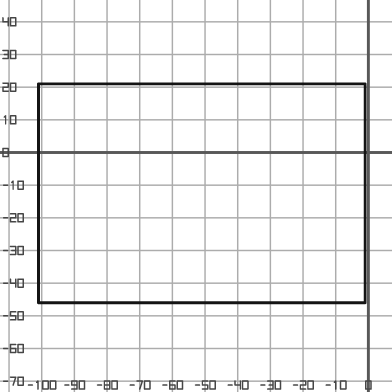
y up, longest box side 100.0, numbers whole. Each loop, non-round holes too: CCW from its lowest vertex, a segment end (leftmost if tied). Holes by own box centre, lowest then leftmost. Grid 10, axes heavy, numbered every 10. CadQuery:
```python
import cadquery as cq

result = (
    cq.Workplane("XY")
    .moveTo(-101.0, -46.0)
    .lineTo(-1.0, -46.0)
    .lineTo(-1.0, 21.0)
    .lineTo(-101.0, 21.0)
    .close()
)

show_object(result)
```